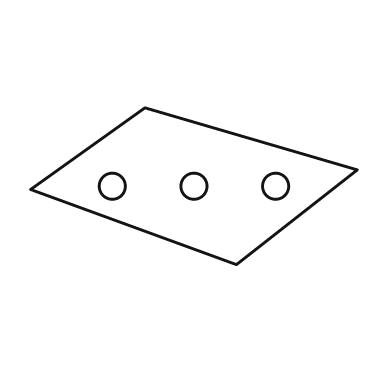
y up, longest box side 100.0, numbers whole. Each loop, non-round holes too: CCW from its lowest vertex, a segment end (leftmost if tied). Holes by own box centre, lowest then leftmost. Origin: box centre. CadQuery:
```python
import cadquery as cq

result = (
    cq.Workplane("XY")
    .moveTo(13.0, -24.0)
    .lineTo(50.0, 5.0)
    .lineTo(-15.0, 24.0)
    .lineTo(-50.0, -1.0)
    .close()
    .moveTo(-25.0, 0.0)
    .circle(4.0)
    .moveTo(0.0, 0.0)
    .circle(4.0)
    .moveTo(25.0, 0.0)
    .circle(4.0)
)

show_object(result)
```